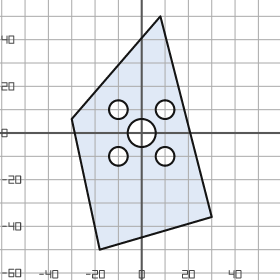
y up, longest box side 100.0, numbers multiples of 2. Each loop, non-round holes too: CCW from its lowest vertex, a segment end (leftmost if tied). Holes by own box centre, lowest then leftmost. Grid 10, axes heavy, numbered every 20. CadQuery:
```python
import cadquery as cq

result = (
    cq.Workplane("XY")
    .moveTo(-18.0, -50.0)
    .lineTo(30.0, -36.0)
    .lineTo(8.0, 50.0)
    .lineTo(-30.0, 6.0)
    .close()
    .moveTo(-10.0, -10.0)
    .circle(4.0)
    .moveTo(10.0, -10.0)
    .circle(4.0)
    .moveTo(0.0, 0.0)
    .circle(6.0)
    .moveTo(-10.0, 10.0)
    .circle(4.0)
    .moveTo(10.0, 10.0)
    .circle(4.0)
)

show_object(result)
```